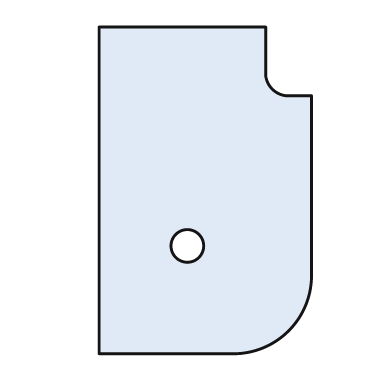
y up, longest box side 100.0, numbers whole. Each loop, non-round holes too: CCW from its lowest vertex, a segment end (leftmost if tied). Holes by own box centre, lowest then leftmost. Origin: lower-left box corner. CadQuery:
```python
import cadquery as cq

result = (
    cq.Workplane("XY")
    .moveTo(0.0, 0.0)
    .lineTo(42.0, 0.0)
    .threePointArc((58.0, 7.0), (65.0, 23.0))
    .lineTo(65.0, 79.0)
    .lineTo(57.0, 79.0)
    .threePointArc((53.0, 81.0), (51.0, 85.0))
    .lineTo(51.0, 100.0)
    .lineTo(0.0, 100.0)
    .close()
    .moveTo(27.0, 33.0)
    .circle(5.0)
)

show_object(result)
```